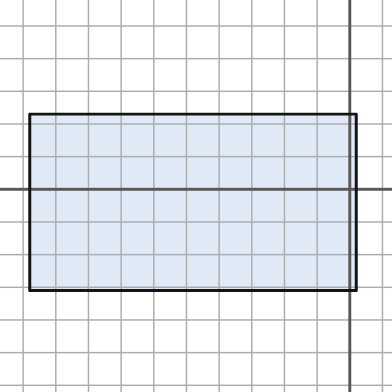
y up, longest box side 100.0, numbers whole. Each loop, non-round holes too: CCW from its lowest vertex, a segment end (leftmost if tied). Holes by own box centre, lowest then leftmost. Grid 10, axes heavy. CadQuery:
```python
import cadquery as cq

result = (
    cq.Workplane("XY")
    .moveTo(-98.0, -31.0)
    .lineTo(2.0, -31.0)
    .lineTo(2.0, 23.0)
    .lineTo(-98.0, 23.0)
    .close()
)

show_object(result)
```